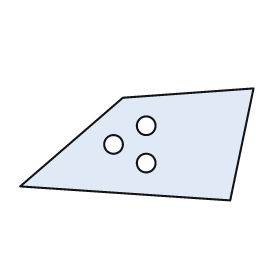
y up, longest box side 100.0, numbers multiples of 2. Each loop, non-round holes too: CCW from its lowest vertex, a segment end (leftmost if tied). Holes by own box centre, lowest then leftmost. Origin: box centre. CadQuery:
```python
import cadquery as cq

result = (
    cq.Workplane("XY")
    .moveTo(40.0, -24.0)
    .lineTo(50.0, 24.0)
    .lineTo(-6.0, 20.0)
    .lineTo(-50.0, -18.0)
    .close()
    .moveTo(4.0, -8.0)
    .circle(4.0)
    .moveTo(-10.0, 0.0)
    .circle(4.0)
    .moveTo(4.0, 8.0)
    .circle(4.0)
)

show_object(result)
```